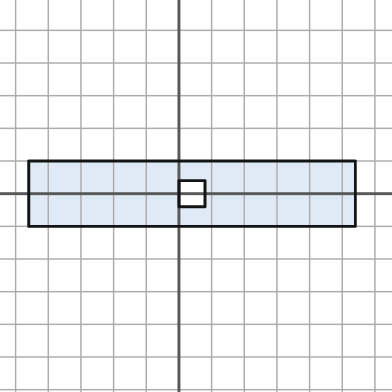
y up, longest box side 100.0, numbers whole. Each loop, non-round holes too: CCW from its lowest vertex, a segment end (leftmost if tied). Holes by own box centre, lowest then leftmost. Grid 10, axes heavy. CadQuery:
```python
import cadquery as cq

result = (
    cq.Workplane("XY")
    .moveTo(-46.0, -10.0)
    .lineTo(54.0, -10.0)
    .lineTo(54.0, 10.0)
    .lineTo(-46.0, 10.0)
    .close()
    .moveTo(0.0, -4.0)
    .lineTo(8.0, -4.0)
    .lineTo(8.0, 4.0)
    .lineTo(0.0, 4.0)
    .close()
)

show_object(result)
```